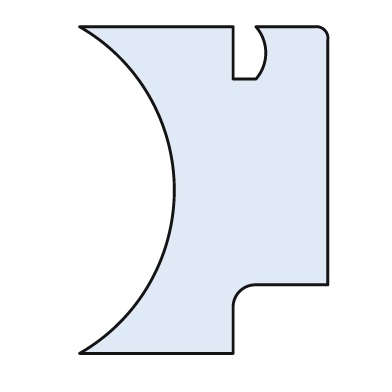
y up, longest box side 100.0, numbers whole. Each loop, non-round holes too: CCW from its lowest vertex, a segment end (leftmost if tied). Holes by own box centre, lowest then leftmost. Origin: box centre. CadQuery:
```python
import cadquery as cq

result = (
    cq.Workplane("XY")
    .moveTo(-38.0, -50.0)
    .lineTo(9.0, -50.0)
    .lineTo(9.0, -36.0)
    .threePointArc((11.0, -31.0), (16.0, -29.0))
    .lineTo(38.0, -29.0)
    .lineTo(38.0, 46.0)
    .threePointArc((37.0, 49.0), (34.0, 50.0))
    .lineTo(16.0, 50.0)
    .threePointArc((19.0, 42.0), (16.0, 34.0))
    .lineTo(9.0, 34.0)
    .lineTo(9.0, 50.0)
    .lineTo(-38.0, 50.0)
    .threePointArc((-9.0, 0.0), (-38.0, -50.0))
    .close()
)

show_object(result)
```